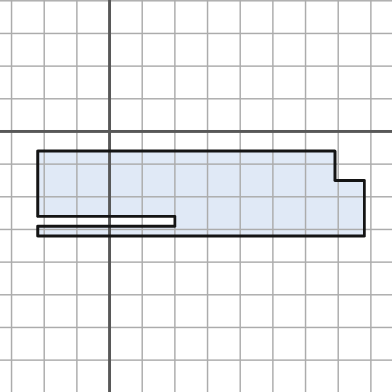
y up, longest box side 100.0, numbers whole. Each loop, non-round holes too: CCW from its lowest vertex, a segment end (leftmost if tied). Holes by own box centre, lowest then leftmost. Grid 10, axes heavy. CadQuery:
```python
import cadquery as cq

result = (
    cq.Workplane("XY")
    .moveTo(-22.0, -32.0)
    .lineTo(78.0, -32.0)
    .lineTo(78.0, -15.0)
    .lineTo(69.0, -15.0)
    .lineTo(69.0, -6.0)
    .lineTo(-22.0, -6.0)
    .lineTo(-22.0, -26.0)
    .lineTo(20.0, -26.0)
    .lineTo(20.0, -29.0)
    .lineTo(-22.0, -29.0)
    .close()
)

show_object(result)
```